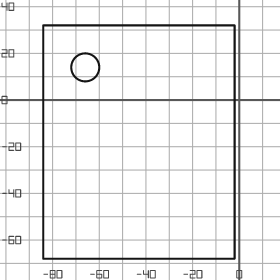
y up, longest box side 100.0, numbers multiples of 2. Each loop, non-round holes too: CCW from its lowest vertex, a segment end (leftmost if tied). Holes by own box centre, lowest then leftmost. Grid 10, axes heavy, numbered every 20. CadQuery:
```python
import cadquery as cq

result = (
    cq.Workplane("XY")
    .moveTo(-84.0, -68.0)
    .lineTo(-2.0, -68.0)
    .lineTo(-2.0, 32.0)
    .lineTo(-84.0, 32.0)
    .close()
    .moveTo(-66.0, 14.0)
    .circle(6.0)
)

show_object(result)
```